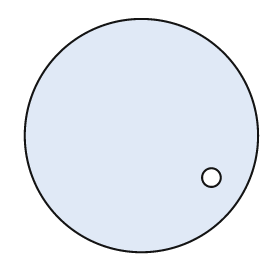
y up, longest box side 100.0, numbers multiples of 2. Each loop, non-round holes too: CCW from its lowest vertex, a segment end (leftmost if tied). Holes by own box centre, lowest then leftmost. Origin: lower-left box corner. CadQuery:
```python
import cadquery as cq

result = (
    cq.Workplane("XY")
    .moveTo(50.0, 50.0)
    .circle(50.0)
    .moveTo(80.0, 32.0)
    .circle(4.0)
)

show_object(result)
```